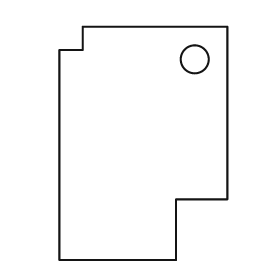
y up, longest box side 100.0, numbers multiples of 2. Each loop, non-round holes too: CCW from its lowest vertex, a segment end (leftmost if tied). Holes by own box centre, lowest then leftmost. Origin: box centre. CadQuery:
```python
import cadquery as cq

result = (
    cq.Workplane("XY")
    .moveTo(-36.0, -50.0)
    .lineTo(14.0, -50.0)
    .lineTo(14.0, -24.0)
    .lineTo(36.0, -24.0)
    .lineTo(36.0, 50.0)
    .lineTo(-26.0, 50.0)
    .lineTo(-26.0, 40.0)
    .lineTo(-36.0, 40.0)
    .close()
    .moveTo(22.0, 36.0)
    .circle(6.0)
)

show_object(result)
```